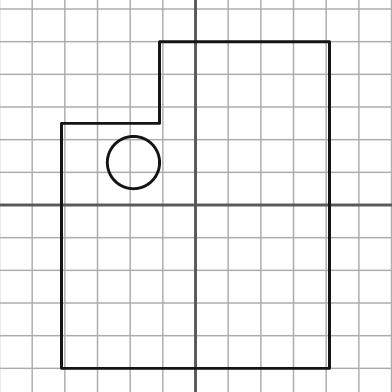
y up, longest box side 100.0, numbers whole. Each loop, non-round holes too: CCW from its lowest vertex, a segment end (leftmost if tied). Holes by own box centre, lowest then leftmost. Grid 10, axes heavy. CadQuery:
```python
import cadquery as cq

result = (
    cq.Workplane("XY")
    .moveTo(-41.0, -50.0)
    .lineTo(41.0, -50.0)
    .lineTo(41.0, 50.0)
    .lineTo(-11.0, 50.0)
    .lineTo(-11.0, 25.0)
    .lineTo(-41.0, 25.0)
    .close()
    .moveTo(-19.0, 13.0)
    .circle(8.0)
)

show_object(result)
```